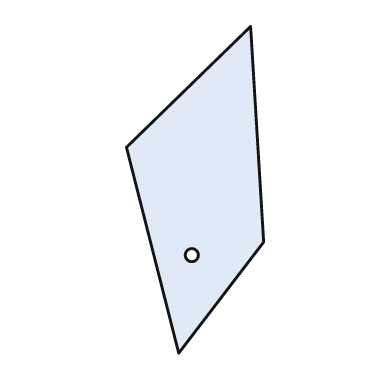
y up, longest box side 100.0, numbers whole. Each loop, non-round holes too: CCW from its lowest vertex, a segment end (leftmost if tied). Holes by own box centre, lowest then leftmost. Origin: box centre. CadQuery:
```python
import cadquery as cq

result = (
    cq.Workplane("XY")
    .moveTo(-5.0, -50.0)
    .lineTo(21.0, -16.0)
    .lineTo(17.0, 50.0)
    .lineTo(-21.0, 13.0)
    .close()
    .moveTo(-1.0, -20.0)
    .circle(2.0)
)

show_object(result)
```